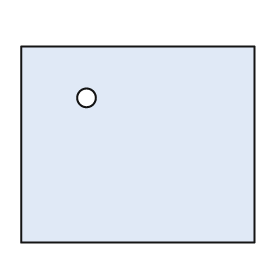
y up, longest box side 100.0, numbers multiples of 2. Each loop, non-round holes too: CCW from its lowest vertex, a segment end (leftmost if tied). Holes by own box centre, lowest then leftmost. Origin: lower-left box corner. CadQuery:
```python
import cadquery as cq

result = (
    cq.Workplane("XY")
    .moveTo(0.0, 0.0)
    .lineTo(100.0, 0.0)
    .lineTo(100.0, 84.0)
    .lineTo(0.0, 84.0)
    .close()
    .moveTo(28.0, 62.0)
    .circle(4.0)
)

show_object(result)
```